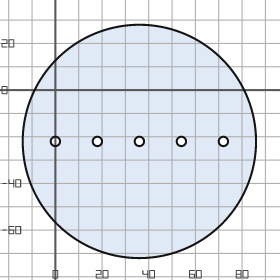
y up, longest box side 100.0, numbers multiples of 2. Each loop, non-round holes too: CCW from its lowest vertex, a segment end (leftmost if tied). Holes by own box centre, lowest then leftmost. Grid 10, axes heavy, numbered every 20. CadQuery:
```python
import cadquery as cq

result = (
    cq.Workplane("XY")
    .moveTo(36.0, -22.0)
    .circle(50.0)
    .moveTo(0.0, -22.0)
    .circle(2.0)
    .moveTo(18.0, -22.0)
    .circle(2.0)
    .moveTo(36.0, -22.0)
    .circle(2.0)
    .moveTo(54.0, -22.0)
    .circle(2.0)
    .moveTo(72.0, -22.0)
    .circle(2.0)
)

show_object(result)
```